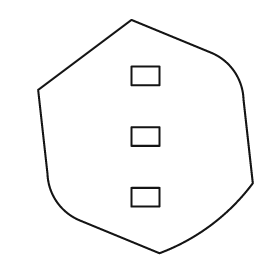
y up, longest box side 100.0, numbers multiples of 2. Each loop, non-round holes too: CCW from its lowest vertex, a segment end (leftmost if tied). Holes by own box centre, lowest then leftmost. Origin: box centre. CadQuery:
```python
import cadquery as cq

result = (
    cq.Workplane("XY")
    .moveTo(6.0, -50.0)
    .threePointArc((28.0, -38.0), (46.0, -20.0))
    .lineTo(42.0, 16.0)
    .threePointArc((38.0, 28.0), (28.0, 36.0))
    .lineTo(-6.0, 50.0)
    .lineTo(-46.0, 20.0)
    .lineTo(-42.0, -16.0)
    .threePointArc((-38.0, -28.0), (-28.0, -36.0))
    .close()
    .moveTo(-6.0, -30.0)
    .lineTo(6.0, -30.0)
    .lineTo(6.0, -22.0)
    .lineTo(-6.0, -22.0)
    .close()
    .moveTo(-6.0, -4.0)
    .lineTo(6.0, -4.0)
    .lineTo(6.0, 4.0)
    .lineTo(-6.0, 4.0)
    .close()
    .moveTo(-6.0, 22.0)
    .lineTo(6.0, 22.0)
    .lineTo(6.0, 30.0)
    .lineTo(-6.0, 30.0)
    .close()
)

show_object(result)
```